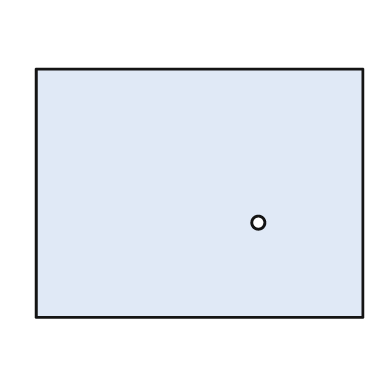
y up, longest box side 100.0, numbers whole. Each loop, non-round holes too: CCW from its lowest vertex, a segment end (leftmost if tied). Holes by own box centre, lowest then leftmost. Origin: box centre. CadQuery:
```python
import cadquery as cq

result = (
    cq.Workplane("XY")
    .moveTo(-50.0, -38.0)
    .lineTo(50.0, -38.0)
    .lineTo(50.0, 38.0)
    .lineTo(-50.0, 38.0)
    .close()
    .moveTo(18.0, -9.0)
    .circle(2.0)
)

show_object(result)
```